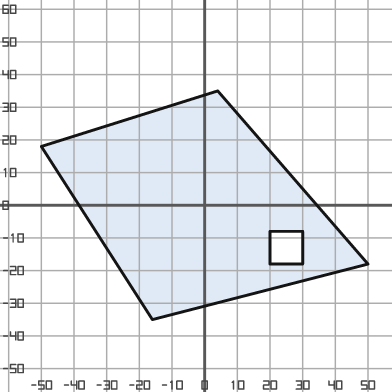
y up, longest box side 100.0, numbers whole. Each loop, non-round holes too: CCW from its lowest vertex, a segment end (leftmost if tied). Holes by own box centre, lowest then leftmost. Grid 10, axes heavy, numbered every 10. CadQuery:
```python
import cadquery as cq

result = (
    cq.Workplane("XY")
    .moveTo(-16.0, -35.0)
    .lineTo(50.0, -18.0)
    .lineTo(4.0, 35.0)
    .lineTo(-50.0, 18.0)
    .close()
    .moveTo(20.0, -18.0)
    .lineTo(30.0, -18.0)
    .lineTo(30.0, -8.0)
    .lineTo(20.0, -8.0)
    .close()
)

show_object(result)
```